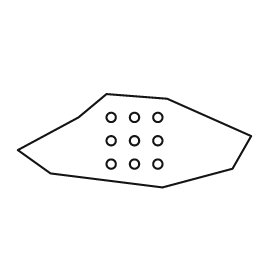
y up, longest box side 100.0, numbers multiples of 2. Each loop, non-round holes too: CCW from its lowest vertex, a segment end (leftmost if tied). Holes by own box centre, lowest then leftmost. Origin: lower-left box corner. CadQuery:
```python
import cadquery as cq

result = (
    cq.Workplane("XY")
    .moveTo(62.0, 0.0)
    .lineTo(92.0, 8.0)
    .lineTo(100.0, 22.0)
    .lineTo(64.0, 38.0)
    .lineTo(38.0, 40.0)
    .lineTo(26.0, 30.0)
    .lineTo(0.0, 16.0)
    .lineTo(14.0, 6.0)
    .close()
    .moveTo(40.0, 10.0)
    .circle(2.0)
    .moveTo(50.0, 10.0)
    .circle(2.0)
    .moveTo(60.0, 10.0)
    .circle(2.0)
    .moveTo(40.0, 20.0)
    .circle(2.0)
    .moveTo(50.0, 20.0)
    .circle(2.0)
    .moveTo(60.0, 20.0)
    .circle(2.0)
    .moveTo(40.0, 30.0)
    .circle(2.0)
    .moveTo(50.0, 30.0)
    .circle(2.0)
    .moveTo(60.0, 30.0)
    .circle(2.0)
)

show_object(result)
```